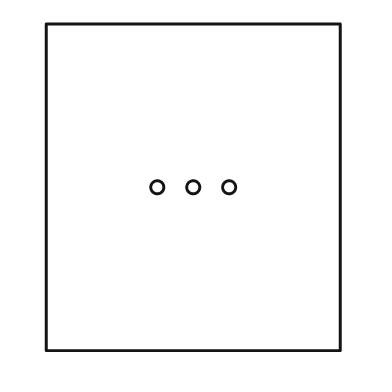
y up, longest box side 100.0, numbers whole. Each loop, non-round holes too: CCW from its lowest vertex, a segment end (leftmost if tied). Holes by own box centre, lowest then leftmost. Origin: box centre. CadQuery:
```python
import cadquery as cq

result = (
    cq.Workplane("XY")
    .moveTo(-45.0, -50.0)
    .lineTo(45.0, -50.0)
    .lineTo(45.0, 50.0)
    .lineTo(-45.0, 50.0)
    .close()
    .moveTo(-11.0, 0.0)
    .circle(2.0)
    .moveTo(0.0, 0.0)
    .circle(2.0)
    .moveTo(11.0, 0.0)
    .circle(2.0)
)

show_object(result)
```